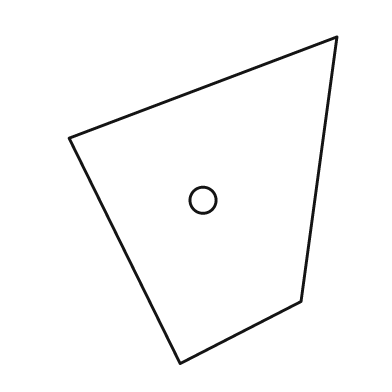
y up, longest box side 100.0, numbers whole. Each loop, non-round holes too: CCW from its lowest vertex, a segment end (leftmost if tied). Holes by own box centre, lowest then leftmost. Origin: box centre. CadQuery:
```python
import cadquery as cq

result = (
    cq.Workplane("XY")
    .moveTo(-7.0, -50.0)
    .lineTo(30.0, -31.0)
    .lineTo(41.0, 50.0)
    .lineTo(-41.0, 19.0)
    .close()
    .moveTo(0.0, 0.0)
    .circle(4.0)
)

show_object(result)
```